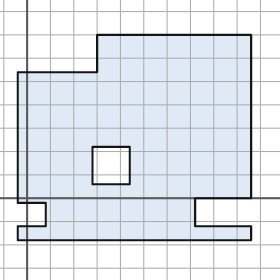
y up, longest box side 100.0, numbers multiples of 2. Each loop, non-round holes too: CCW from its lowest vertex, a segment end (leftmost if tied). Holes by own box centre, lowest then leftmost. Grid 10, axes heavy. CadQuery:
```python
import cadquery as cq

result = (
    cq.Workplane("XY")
    .moveTo(-4.0, -18.0)
    .lineTo(96.0, -18.0)
    .lineTo(96.0, -12.0)
    .lineTo(72.0, -12.0)
    .lineTo(72.0, 0.0)
    .lineTo(96.0, 0.0)
    .lineTo(96.0, 70.0)
    .lineTo(30.0, 70.0)
    .lineTo(30.0, 54.0)
    .lineTo(-4.0, 54.0)
    .lineTo(-4.0, -2.0)
    .lineTo(8.0, -2.0)
    .lineTo(8.0, -12.0)
    .lineTo(-4.0, -12.0)
    .close()
    .moveTo(28.0, 6.0)
    .lineTo(44.0, 6.0)
    .lineTo(44.0, 22.0)
    .lineTo(28.0, 22.0)
    .close()
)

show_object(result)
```